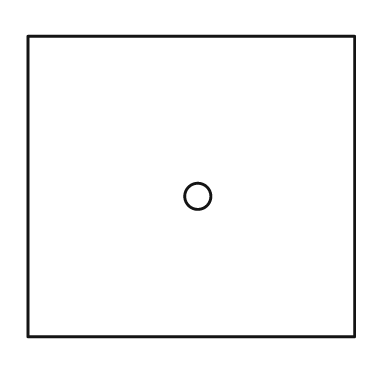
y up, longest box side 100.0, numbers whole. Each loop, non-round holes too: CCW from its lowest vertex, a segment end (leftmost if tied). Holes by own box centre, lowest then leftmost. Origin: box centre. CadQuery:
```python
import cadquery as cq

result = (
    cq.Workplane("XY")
    .moveTo(-50.0, -46.0)
    .lineTo(50.0, -46.0)
    .lineTo(50.0, 46.0)
    .lineTo(-50.0, 46.0)
    .close()
    .moveTo(2.0, -3.0)
    .circle(4.0)
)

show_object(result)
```